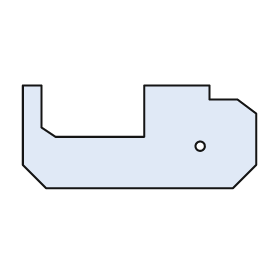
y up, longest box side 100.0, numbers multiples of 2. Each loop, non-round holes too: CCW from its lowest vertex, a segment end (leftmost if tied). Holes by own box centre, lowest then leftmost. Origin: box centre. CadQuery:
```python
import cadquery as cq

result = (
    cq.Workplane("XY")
    .moveTo(-40.0, -22.0)
    .lineTo(40.0, -22.0)
    .lineTo(50.0, -12.0)
    .lineTo(50.0, 10.0)
    .lineTo(42.0, 16.0)
    .lineTo(30.0, 16.0)
    .lineTo(30.0, 22.0)
    .lineTo(2.0, 22.0)
    .lineTo(2.0, 0.0)
    .lineTo(-36.0, 0.0)
    .lineTo(-42.0, 4.0)
    .lineTo(-42.0, 22.0)
    .lineTo(-50.0, 22.0)
    .lineTo(-50.0, -12.0)
    .close()
    .moveTo(26.0, -4.0)
    .circle(2.0)
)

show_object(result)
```